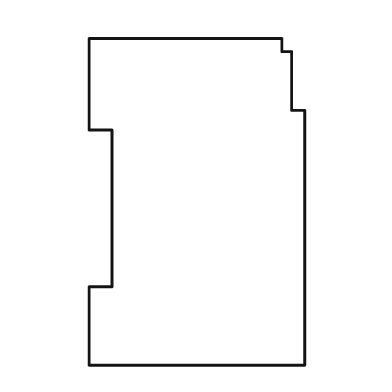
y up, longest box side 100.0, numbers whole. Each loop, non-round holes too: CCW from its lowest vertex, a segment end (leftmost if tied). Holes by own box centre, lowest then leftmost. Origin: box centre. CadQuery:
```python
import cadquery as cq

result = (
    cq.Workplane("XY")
    .moveTo(-33.0, -50.0)
    .lineTo(33.0, -50.0)
    .lineTo(33.0, 28.0)
    .lineTo(29.0, 28.0)
    .lineTo(29.0, 46.0)
    .lineTo(26.0, 46.0)
    .lineTo(26.0, 50.0)
    .lineTo(-33.0, 50.0)
    .lineTo(-33.0, 22.0)
    .lineTo(-26.0, 22.0)
    .lineTo(-26.0, -26.0)
    .lineTo(-33.0, -26.0)
    .close()
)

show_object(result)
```